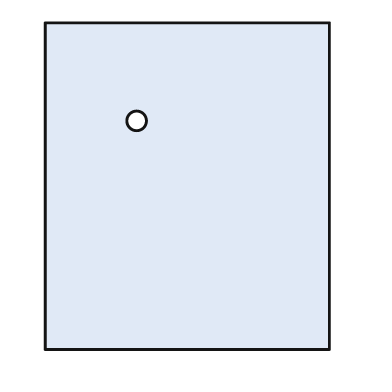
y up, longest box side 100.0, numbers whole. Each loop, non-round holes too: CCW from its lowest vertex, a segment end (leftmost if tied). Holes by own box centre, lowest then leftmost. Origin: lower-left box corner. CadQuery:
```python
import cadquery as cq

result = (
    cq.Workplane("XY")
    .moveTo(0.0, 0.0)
    .lineTo(87.0, 0.0)
    .lineTo(87.0, 100.0)
    .lineTo(0.0, 100.0)
    .close()
    .moveTo(28.0, 70.0)
    .circle(3.0)
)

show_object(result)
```